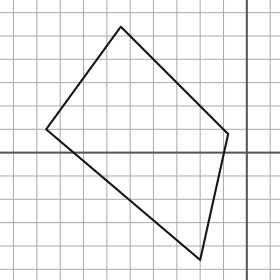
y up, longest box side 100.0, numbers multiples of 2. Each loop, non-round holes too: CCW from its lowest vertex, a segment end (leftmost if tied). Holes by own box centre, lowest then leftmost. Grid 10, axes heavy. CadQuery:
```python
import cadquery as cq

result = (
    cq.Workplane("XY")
    .moveTo(-20.0, -46.0)
    .lineTo(-8.0, 8.0)
    .lineTo(-54.0, 54.0)
    .lineTo(-86.0, 10.0)
    .close()
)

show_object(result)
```